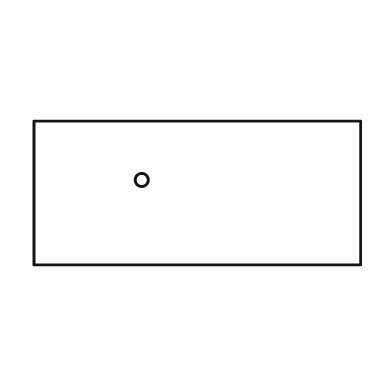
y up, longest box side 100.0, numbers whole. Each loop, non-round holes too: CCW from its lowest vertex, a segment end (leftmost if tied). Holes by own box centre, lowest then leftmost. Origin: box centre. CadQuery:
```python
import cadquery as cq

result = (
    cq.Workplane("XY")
    .moveTo(-50.0, -22.0)
    .lineTo(50.0, -22.0)
    .lineTo(50.0, 22.0)
    .lineTo(-50.0, 22.0)
    .close()
    .moveTo(-17.0, 4.0)
    .circle(2.0)
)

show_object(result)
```